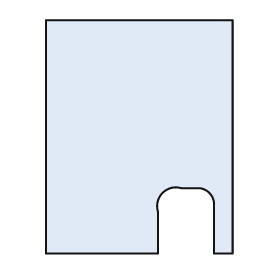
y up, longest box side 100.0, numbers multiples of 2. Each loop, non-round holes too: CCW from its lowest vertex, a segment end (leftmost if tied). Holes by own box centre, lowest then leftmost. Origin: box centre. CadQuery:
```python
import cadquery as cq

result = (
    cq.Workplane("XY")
    .moveTo(-40.0, -50.0)
    .lineTo(8.0, -50.0)
    .lineTo(8.0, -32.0)
    .threePointArc((10.0, -24.0), (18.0, -22.0))
    .lineTo(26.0, -22.0)
    .threePointArc((30.0, -24.0), (32.0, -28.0))
    .lineTo(32.0, -50.0)
    .lineTo(40.0, -50.0)
    .lineTo(40.0, 50.0)
    .lineTo(-40.0, 50.0)
    .close()
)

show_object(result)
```